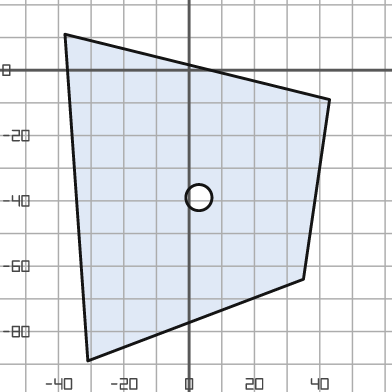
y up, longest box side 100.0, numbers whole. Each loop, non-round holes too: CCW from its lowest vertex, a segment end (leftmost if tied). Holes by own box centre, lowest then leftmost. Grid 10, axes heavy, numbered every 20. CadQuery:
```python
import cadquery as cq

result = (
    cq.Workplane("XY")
    .moveTo(-31.0, -89.0)
    .lineTo(35.0, -64.0)
    .lineTo(43.0, -9.0)
    .lineTo(-38.0, 11.0)
    .close()
    .moveTo(3.0, -39.0)
    .circle(4.0)
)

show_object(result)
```